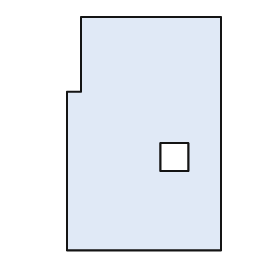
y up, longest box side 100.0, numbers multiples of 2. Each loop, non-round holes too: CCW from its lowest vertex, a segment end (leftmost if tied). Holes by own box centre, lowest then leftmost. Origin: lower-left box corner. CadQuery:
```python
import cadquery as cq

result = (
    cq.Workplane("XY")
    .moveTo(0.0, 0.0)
    .lineTo(66.0, 0.0)
    .lineTo(66.0, 100.0)
    .lineTo(6.0, 100.0)
    .lineTo(6.0, 68.0)
    .lineTo(0.0, 68.0)
    .close()
    .moveTo(40.0, 34.0)
    .lineTo(52.0, 34.0)
    .lineTo(52.0, 46.0)
    .lineTo(40.0, 46.0)
    .close()
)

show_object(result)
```